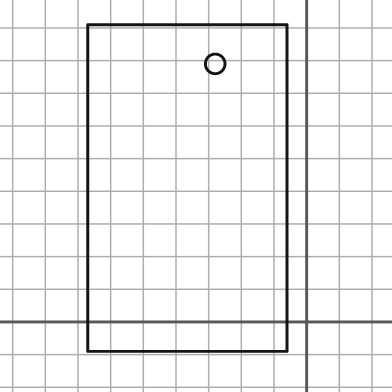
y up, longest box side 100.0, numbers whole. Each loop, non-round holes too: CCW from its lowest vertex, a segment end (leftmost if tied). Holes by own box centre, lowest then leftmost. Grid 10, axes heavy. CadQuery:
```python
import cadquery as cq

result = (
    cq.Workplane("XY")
    .moveTo(-67.0, -9.0)
    .lineTo(-6.0, -9.0)
    .lineTo(-6.0, 91.0)
    .lineTo(-67.0, 91.0)
    .close()
    .moveTo(-28.0, 79.0)
    .circle(3.0)
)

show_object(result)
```